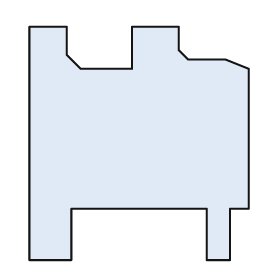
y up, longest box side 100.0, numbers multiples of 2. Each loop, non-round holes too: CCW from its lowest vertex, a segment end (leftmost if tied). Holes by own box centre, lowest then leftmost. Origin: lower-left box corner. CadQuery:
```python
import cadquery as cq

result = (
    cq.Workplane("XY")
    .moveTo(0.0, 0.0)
    .lineTo(18.0, 0.0)
    .lineTo(18.0, 22.0)
    .lineTo(76.0, 22.0)
    .lineTo(76.0, 0.0)
    .lineTo(86.0, 0.0)
    .lineTo(86.0, 22.0)
    .lineTo(94.0, 22.0)
    .lineTo(94.0, 82.0)
    .lineTo(84.0, 86.0)
    .lineTo(68.0, 86.0)
    .lineTo(64.0, 90.0)
    .lineTo(64.0, 100.0)
    .lineTo(44.0, 100.0)
    .lineTo(44.0, 82.0)
    .lineTo(22.0, 82.0)
    .lineTo(16.0, 88.0)
    .lineTo(16.0, 100.0)
    .lineTo(0.0, 100.0)
    .close()
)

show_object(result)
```